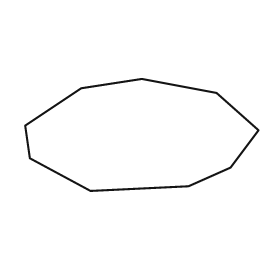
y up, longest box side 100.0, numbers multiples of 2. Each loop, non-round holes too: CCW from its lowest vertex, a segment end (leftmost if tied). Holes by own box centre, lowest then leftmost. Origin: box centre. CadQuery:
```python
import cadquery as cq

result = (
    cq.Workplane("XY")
    .moveTo(-22.0, -24.0)
    .lineTo(20.0, -22.0)
    .lineTo(38.0, -14.0)
    .lineTo(50.0, 2.0)
    .lineTo(32.0, 18.0)
    .lineTo(0.0, 24.0)
    .lineTo(-26.0, 20.0)
    .lineTo(-50.0, 4.0)
    .lineTo(-48.0, -10.0)
    .close()
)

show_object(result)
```